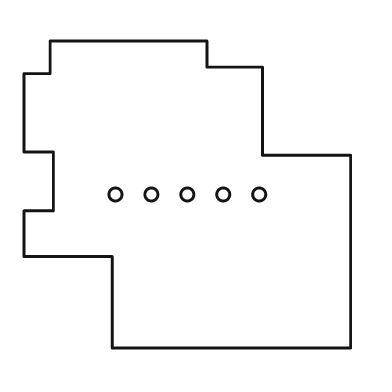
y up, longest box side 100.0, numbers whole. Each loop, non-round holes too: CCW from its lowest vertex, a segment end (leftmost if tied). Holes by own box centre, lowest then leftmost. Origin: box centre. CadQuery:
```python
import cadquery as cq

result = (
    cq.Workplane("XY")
    .moveTo(-23.0, -47.0)
    .lineTo(50.0, -47.0)
    .lineTo(50.0, 12.0)
    .lineTo(23.0, 12.0)
    .lineTo(23.0, 39.0)
    .lineTo(6.0, 39.0)
    .lineTo(6.0, 47.0)
    .lineTo(-42.0, 47.0)
    .lineTo(-42.0, 37.0)
    .lineTo(-50.0, 37.0)
    .lineTo(-50.0, 13.0)
    .lineTo(-41.0, 13.0)
    .lineTo(-41.0, -5.0)
    .lineTo(-50.0, -5.0)
    .lineTo(-50.0, -19.0)
    .lineTo(-23.0, -19.0)
    .close()
    .moveTo(-22.0, 0.0)
    .circle(2.0)
    .moveTo(-11.0, 0.0)
    .circle(2.0)
    .moveTo(0.0, 0.0)
    .circle(2.0)
    .moveTo(11.0, 0.0)
    .circle(2.0)
    .moveTo(22.0, 0.0)
    .circle(2.0)
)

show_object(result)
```